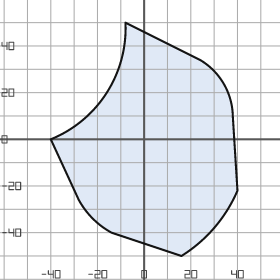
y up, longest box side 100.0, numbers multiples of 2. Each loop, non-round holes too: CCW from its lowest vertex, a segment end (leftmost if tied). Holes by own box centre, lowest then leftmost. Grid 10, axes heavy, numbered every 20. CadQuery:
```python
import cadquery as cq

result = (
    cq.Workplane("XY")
    .moveTo(16.0, -50.0)
    .threePointArc((30.0, -38.0), (40.0, -22.0))
    .lineTo(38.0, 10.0)
    .threePointArc((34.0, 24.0), (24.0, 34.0))
    .lineTo(-8.0, 50.0)
    .threePointArc((-16.0, 20.0), (-40.0, 0.0))
    .lineTo(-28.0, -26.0)
    .threePointArc((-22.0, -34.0), (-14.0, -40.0))
    .close()
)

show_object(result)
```